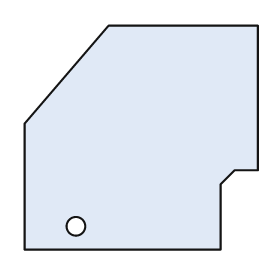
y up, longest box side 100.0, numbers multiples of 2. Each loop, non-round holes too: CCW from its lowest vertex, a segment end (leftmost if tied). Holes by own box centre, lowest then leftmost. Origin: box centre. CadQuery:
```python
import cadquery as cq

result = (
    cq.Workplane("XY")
    .moveTo(-50.0, -48.0)
    .lineTo(34.0, -48.0)
    .lineTo(34.0, -20.0)
    .lineTo(40.0, -14.0)
    .lineTo(50.0, -14.0)
    .lineTo(50.0, 48.0)
    .lineTo(-14.0, 48.0)
    .lineTo(-50.0, 6.0)
    .close()
    .moveTo(-28.0, -38.0)
    .circle(4.0)
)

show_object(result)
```